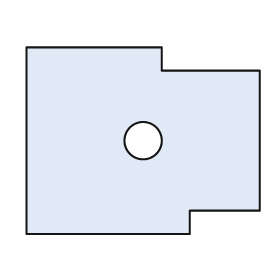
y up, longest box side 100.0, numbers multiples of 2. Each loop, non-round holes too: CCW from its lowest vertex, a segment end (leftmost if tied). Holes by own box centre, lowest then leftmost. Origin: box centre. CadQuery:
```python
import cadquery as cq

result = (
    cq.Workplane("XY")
    .moveTo(-50.0, -40.0)
    .lineTo(20.0, -40.0)
    .lineTo(20.0, -30.0)
    .lineTo(50.0, -30.0)
    .lineTo(50.0, 30.0)
    .lineTo(8.0, 30.0)
    .lineTo(8.0, 40.0)
    .lineTo(-50.0, 40.0)
    .close()
    .moveTo(0.0, 0.0)
    .circle(8.0)
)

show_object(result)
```